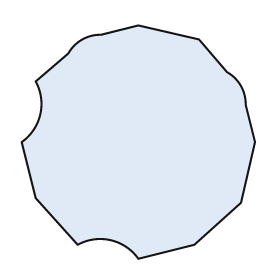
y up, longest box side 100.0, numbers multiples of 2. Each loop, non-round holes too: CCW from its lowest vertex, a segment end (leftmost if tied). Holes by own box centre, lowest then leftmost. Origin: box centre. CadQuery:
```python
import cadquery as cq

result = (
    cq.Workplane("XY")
    .moveTo(0.0, -50.0)
    .lineTo(24.0, -44.0)
    .lineTo(44.0, -26.0)
    .lineTo(50.0, 0.0)
    .lineTo(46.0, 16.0)
    .threePointArc((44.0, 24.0), (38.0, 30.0))
    .lineTo(26.0, 44.0)
    .lineTo(0.0, 50.0)
    .lineTo(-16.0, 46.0)
    .threePointArc((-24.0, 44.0), (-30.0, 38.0))
    .lineTo(-44.0, 26.0)
    .threePointArc((-42.0, 12.0), (-50.0, 0.0))
    .lineTo(-44.0, -24.0)
    .lineTo(-26.0, -44.0)
    .threePointArc((-12.0, -42.0), (0.0, -50.0))
    .close()
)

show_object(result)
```